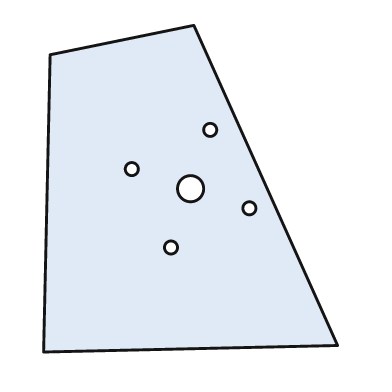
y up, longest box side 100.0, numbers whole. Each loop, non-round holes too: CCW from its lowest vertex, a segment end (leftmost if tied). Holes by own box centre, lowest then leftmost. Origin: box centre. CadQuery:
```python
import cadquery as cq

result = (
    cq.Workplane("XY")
    .moveTo(-45.0, -50.0)
    .lineTo(45.0, -48.0)
    .lineTo(1.0, 50.0)
    .lineTo(-43.0, 41.0)
    .close()
    .moveTo(-6.0, -18.0)
    .circle(2.0)
    .moveTo(18.0, -6.0)
    .circle(2.0)
    .moveTo(0.0, 0.0)
    .circle(4.0)
    .moveTo(-18.0, 6.0)
    .circle(2.0)
    .moveTo(6.0, 18.0)
    .circle(2.0)
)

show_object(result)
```